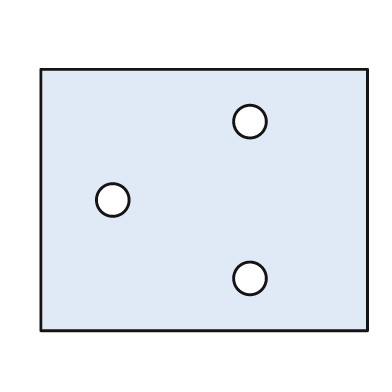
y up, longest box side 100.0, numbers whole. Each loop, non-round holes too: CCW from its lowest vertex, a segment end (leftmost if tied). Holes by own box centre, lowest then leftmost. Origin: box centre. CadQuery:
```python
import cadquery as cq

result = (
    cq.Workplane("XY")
    .moveTo(-50.0, -40.0)
    .lineTo(50.0, -40.0)
    .lineTo(50.0, 40.0)
    .lineTo(-50.0, 40.0)
    .close()
    .moveTo(14.0, -24.0)
    .circle(5.0)
    .moveTo(-28.0, 0.0)
    .circle(5.0)
    .moveTo(14.0, 24.0)
    .circle(5.0)
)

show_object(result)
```